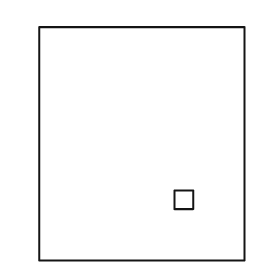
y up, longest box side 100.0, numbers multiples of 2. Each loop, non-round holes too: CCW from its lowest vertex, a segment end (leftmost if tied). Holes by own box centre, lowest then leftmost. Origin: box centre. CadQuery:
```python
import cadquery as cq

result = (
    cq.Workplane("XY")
    .moveTo(-44.0, -50.0)
    .lineTo(44.0, -50.0)
    .lineTo(44.0, 50.0)
    .lineTo(-44.0, 50.0)
    .close()
    .moveTo(14.0, -28.0)
    .lineTo(22.0, -28.0)
    .lineTo(22.0, -20.0)
    .lineTo(14.0, -20.0)
    .close()
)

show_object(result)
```